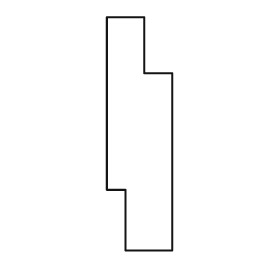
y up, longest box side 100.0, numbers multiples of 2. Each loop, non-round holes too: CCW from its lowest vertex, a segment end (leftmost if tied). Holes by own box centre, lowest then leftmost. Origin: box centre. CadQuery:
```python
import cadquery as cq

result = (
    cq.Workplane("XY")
    .moveTo(-6.0, -50.0)
    .lineTo(14.0, -50.0)
    .lineTo(14.0, 26.0)
    .lineTo(2.0, 26.0)
    .lineTo(2.0, 50.0)
    .lineTo(-14.0, 50.0)
    .lineTo(-14.0, -24.0)
    .lineTo(-6.0, -24.0)
    .close()
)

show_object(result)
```